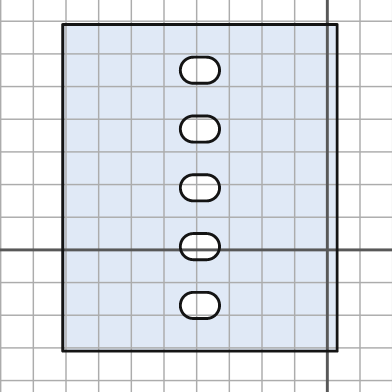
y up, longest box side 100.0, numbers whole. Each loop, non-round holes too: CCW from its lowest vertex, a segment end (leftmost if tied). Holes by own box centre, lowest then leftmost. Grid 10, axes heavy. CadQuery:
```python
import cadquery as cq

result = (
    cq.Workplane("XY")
    .moveTo(-81.0, -31.0)
    .lineTo(3.0, -31.0)
    .lineTo(3.0, 69.0)
    .lineTo(-81.0, 69.0)
    .close()
    .moveTo(-41.0, -21.0)
    .lineTo(-37.0, -21.0)
    .threePointArc((-33.0, -17.0), (-37.0, -13.0))
    .lineTo(-41.0, -13.0)
    .threePointArc((-45.0, -17.0), (-41.0, -21.0))
    .close()
    .moveTo(-41.0, -3.0)
    .lineTo(-37.0, -3.0)
    .threePointArc((-33.0, 1.0), (-37.0, 5.0))
    .lineTo(-41.0, 5.0)
    .threePointArc((-45.0, 1.0), (-41.0, -3.0))
    .close()
    .moveTo(-41.0, 15.0)
    .lineTo(-37.0, 15.0)
    .threePointArc((-33.0, 19.0), (-37.0, 23.0))
    .lineTo(-41.0, 23.0)
    .threePointArc((-45.0, 19.0), (-41.0, 15.0))
    .close()
    .moveTo(-41.0, 33.0)
    .lineTo(-37.0, 33.0)
    .threePointArc((-33.0, 37.0), (-37.0, 41.0))
    .lineTo(-41.0, 41.0)
    .threePointArc((-45.0, 37.0), (-41.0, 33.0))
    .close()
    .moveTo(-41.0, 51.0)
    .lineTo(-37.0, 51.0)
    .threePointArc((-33.0, 55.0), (-37.0, 59.0))
    .lineTo(-41.0, 59.0)
    .threePointArc((-45.0, 55.0), (-41.0, 51.0))
    .close()
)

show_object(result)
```